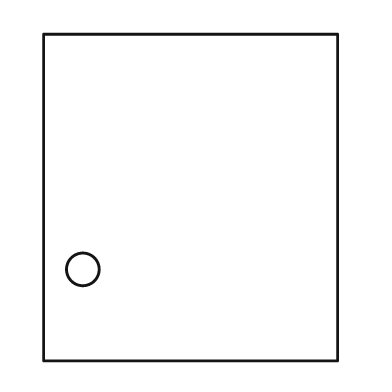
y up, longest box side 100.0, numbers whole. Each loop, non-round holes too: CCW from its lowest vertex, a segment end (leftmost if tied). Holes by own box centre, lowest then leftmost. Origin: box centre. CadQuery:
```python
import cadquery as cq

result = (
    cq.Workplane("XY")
    .moveTo(-45.0, -50.0)
    .lineTo(45.0, -50.0)
    .lineTo(45.0, 50.0)
    .lineTo(-45.0, 50.0)
    .close()
    .moveTo(-33.0, -22.0)
    .circle(5.0)
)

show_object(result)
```